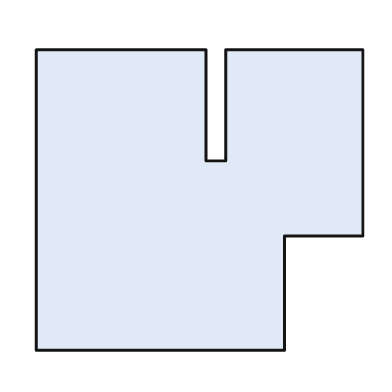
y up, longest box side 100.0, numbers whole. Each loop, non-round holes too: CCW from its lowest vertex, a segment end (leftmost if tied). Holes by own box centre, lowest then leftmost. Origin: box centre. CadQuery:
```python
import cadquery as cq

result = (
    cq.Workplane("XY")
    .moveTo(-50.0, -46.0)
    .lineTo(26.0, -46.0)
    .lineTo(26.0, -11.0)
    .lineTo(50.0, -11.0)
    .lineTo(50.0, 46.0)
    .lineTo(8.0, 46.0)
    .lineTo(8.0, 12.0)
    .lineTo(2.0, 12.0)
    .lineTo(2.0, 46.0)
    .lineTo(-50.0, 46.0)
    .close()
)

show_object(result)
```